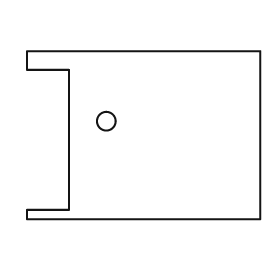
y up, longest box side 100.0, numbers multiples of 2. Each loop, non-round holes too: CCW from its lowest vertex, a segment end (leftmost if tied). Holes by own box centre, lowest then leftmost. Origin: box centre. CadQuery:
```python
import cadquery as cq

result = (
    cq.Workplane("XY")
    .moveTo(-50.0, -36.0)
    .lineTo(50.0, -36.0)
    .lineTo(50.0, 36.0)
    .lineTo(-50.0, 36.0)
    .lineTo(-50.0, 28.0)
    .lineTo(-32.0, 28.0)
    .lineTo(-32.0, -32.0)
    .lineTo(-50.0, -32.0)
    .close()
    .moveTo(-16.0, 6.0)
    .circle(4.0)
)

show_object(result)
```